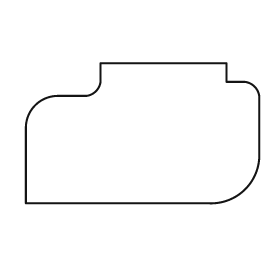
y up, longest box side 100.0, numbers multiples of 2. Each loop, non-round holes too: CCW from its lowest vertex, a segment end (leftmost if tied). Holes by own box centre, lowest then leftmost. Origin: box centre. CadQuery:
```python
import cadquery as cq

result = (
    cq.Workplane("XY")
    .moveTo(-50.0, -30.0)
    .lineTo(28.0, -30.0)
    .threePointArc((44.0, -24.0), (50.0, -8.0))
    .lineTo(50.0, 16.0)
    .threePointArc((48.0, 20.0), (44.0, 22.0))
    .lineTo(36.0, 22.0)
    .lineTo(36.0, 30.0)
    .lineTo(-18.0, 30.0)
    .lineTo(-18.0, 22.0)
    .threePointArc((-20.0, 18.0), (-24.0, 16.0))
    .lineTo(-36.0, 16.0)
    .threePointArc((-46.0, 12.0), (-50.0, 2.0))
    .close()
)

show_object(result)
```